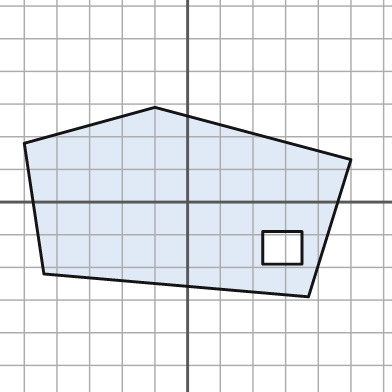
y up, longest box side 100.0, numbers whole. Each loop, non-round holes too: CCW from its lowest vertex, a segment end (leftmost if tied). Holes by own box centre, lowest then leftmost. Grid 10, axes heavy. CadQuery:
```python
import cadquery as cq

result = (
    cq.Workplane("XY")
    .moveTo(37.0, -29.0)
    .lineTo(50.0, 13.0)
    .lineTo(-10.0, 29.0)
    .lineTo(-50.0, 18.0)
    .lineTo(-44.0, -22.0)
    .close()
    .moveTo(23.0, -19.0)
    .lineTo(35.0, -19.0)
    .lineTo(35.0, -9.0)
    .lineTo(23.0, -9.0)
    .close()
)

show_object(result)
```